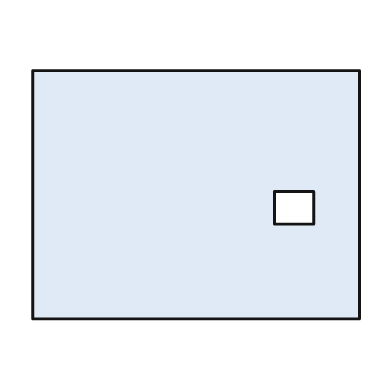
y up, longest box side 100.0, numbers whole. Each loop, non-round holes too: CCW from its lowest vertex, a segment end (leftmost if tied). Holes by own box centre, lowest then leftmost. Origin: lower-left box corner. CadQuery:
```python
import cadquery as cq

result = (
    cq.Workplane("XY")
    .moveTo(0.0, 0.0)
    .lineTo(100.0, 0.0)
    .lineTo(100.0, 76.0)
    .lineTo(0.0, 76.0)
    .close()
    .moveTo(74.0, 29.0)
    .lineTo(86.0, 29.0)
    .lineTo(86.0, 39.0)
    .lineTo(74.0, 39.0)
    .close()
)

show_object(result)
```